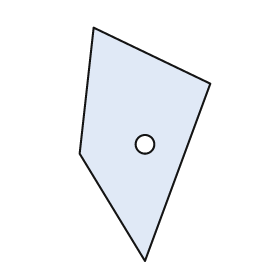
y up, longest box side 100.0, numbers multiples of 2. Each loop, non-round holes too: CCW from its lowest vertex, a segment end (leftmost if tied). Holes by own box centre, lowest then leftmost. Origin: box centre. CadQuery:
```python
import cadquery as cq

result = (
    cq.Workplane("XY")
    .moveTo(0.0, -50.0)
    .lineTo(28.0, 26.0)
    .lineTo(-22.0, 50.0)
    .lineTo(-28.0, -4.0)
    .close()
    .moveTo(0.0, 0.0)
    .circle(4.0)
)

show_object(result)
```